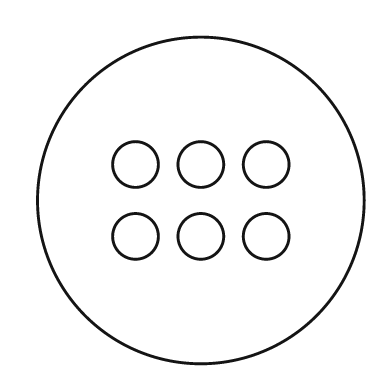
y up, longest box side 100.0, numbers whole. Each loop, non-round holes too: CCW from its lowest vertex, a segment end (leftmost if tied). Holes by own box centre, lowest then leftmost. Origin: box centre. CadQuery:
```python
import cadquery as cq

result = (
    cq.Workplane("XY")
    .moveTo(0.0, 0.0)
    .circle(50.0)
    .moveTo(-20.0, -11.0)
    .circle(7.0)
    .moveTo(0.0, -11.0)
    .circle(7.0)
    .moveTo(20.0, -11.0)
    .circle(7.0)
    .moveTo(-20.0, 11.0)
    .circle(7.0)
    .moveTo(0.0, 11.0)
    .circle(7.0)
    .moveTo(20.0, 11.0)
    .circle(7.0)
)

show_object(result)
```